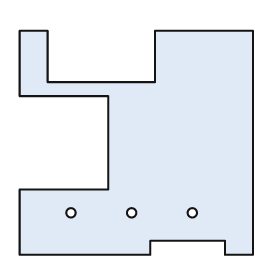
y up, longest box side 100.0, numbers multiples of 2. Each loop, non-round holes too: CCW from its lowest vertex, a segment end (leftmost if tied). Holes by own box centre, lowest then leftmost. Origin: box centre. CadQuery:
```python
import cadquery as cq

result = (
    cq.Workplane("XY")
    .moveTo(-50.0, -48.0)
    .lineTo(6.0, -48.0)
    .lineTo(6.0, -42.0)
    .lineTo(38.0, -42.0)
    .lineTo(38.0, -48.0)
    .lineTo(50.0, -48.0)
    .lineTo(50.0, 48.0)
    .lineTo(8.0, 48.0)
    .lineTo(8.0, 26.0)
    .lineTo(-38.0, 26.0)
    .lineTo(-38.0, 48.0)
    .lineTo(-50.0, 48.0)
    .lineTo(-50.0, 20.0)
    .lineTo(-12.0, 20.0)
    .lineTo(-12.0, -20.0)
    .lineTo(-50.0, -20.0)
    .close()
    .moveTo(-28.0, -30.0)
    .circle(2.0)
    .moveTo(-2.0, -30.0)
    .circle(2.0)
    .moveTo(24.0, -30.0)
    .circle(2.0)
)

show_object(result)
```